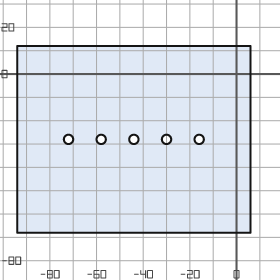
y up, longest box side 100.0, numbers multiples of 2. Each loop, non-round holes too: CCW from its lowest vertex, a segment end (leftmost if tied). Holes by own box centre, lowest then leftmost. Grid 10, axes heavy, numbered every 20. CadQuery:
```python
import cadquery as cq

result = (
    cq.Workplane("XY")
    .moveTo(-94.0, -68.0)
    .lineTo(6.0, -68.0)
    .lineTo(6.0, 12.0)
    .lineTo(-94.0, 12.0)
    .close()
    .moveTo(-72.0, -28.0)
    .circle(2.0)
    .moveTo(-58.0, -28.0)
    .circle(2.0)
    .moveTo(-44.0, -28.0)
    .circle(2.0)
    .moveTo(-30.0, -28.0)
    .circle(2.0)
    .moveTo(-16.0, -28.0)
    .circle(2.0)
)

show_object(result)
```